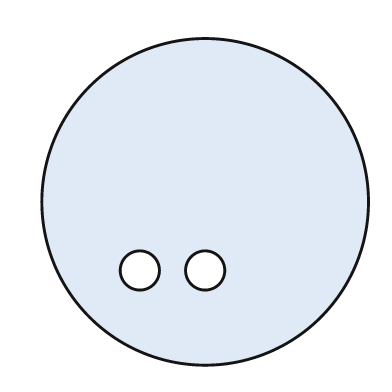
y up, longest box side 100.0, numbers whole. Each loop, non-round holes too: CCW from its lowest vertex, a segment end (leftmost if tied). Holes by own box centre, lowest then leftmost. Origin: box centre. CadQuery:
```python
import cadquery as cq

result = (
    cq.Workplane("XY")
    .moveTo(0.0, 0.0)
    .circle(50.0)
    .moveTo(-20.0, -21.0)
    .circle(6.0)
    .moveTo(0.0, -21.0)
    .circle(6.0)
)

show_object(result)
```